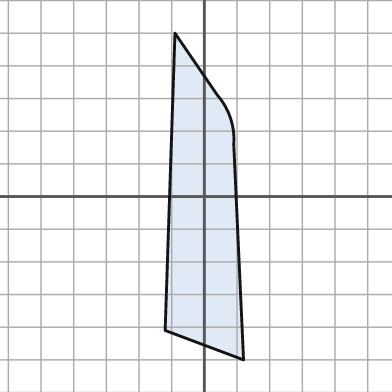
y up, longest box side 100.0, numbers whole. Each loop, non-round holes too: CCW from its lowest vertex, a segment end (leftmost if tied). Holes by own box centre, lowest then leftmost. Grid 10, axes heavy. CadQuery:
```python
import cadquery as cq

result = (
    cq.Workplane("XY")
    .moveTo(12.0, -50.0)
    .lineTo(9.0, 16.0)
    .threePointArc((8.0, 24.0), (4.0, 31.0))
    .lineTo(-9.0, 50.0)
    .lineTo(-12.0, -41.0)
    .close()
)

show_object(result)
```